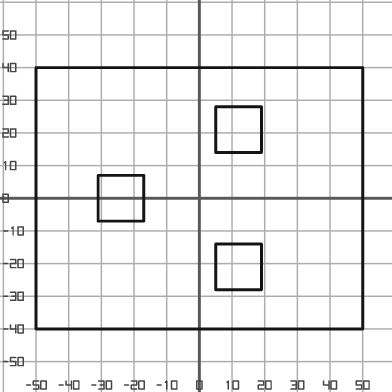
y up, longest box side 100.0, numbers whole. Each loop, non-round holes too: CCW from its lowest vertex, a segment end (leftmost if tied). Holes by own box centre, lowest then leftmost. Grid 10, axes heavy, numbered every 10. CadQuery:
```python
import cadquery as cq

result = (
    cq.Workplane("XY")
    .moveTo(-50.0, -40.0)
    .lineTo(50.0, -40.0)
    .lineTo(50.0, 40.0)
    .lineTo(-50.0, 40.0)
    .close()
    .moveTo(5.0, -28.0)
    .lineTo(19.0, -28.0)
    .lineTo(19.0, -14.0)
    .lineTo(5.0, -14.0)
    .close()
    .moveTo(-31.0, -7.0)
    .lineTo(-17.0, -7.0)
    .lineTo(-17.0, 7.0)
    .lineTo(-31.0, 7.0)
    .close()
    .moveTo(5.0, 14.0)
    .lineTo(19.0, 14.0)
    .lineTo(19.0, 28.0)
    .lineTo(5.0, 28.0)
    .close()
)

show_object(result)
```